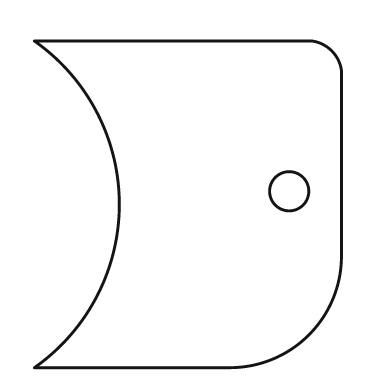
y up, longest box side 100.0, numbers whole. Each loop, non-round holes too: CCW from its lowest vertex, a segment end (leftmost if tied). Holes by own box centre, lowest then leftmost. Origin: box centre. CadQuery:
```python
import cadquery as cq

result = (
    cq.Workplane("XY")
    .moveTo(-47.0, -50.0)
    .lineTo(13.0, -50.0)
    .threePointArc((37.0, -40.0), (47.0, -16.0))
    .lineTo(47.0, 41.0)
    .threePointArc((44.0, 47.0), (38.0, 50.0))
    .lineTo(-47.0, 50.0)
    .threePointArc((-21.0, 0.0), (-47.0, -50.0))
    .close()
    .moveTo(31.0, 4.0)
    .circle(6.0)
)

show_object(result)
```